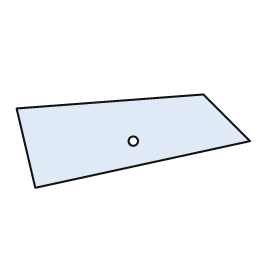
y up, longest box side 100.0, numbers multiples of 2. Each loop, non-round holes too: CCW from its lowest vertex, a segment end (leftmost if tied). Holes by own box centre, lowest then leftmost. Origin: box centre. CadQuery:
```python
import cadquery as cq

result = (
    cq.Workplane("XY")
    .moveTo(-42.0, -20.0)
    .lineTo(50.0, 0.0)
    .lineTo(30.0, 20.0)
    .lineTo(-50.0, 14.0)
    .close()
    .moveTo(0.0, 0.0)
    .circle(2.0)
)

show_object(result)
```